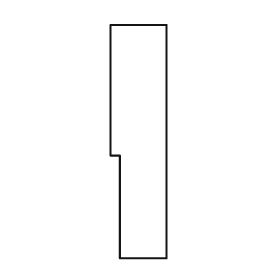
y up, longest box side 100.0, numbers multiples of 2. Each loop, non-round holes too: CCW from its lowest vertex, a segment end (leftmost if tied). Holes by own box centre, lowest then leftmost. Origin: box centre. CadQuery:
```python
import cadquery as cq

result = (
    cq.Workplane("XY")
    .moveTo(-8.0, -50.0)
    .lineTo(12.0, -50.0)
    .lineTo(12.0, 50.0)
    .lineTo(-12.0, 50.0)
    .lineTo(-12.0, -6.0)
    .lineTo(-8.0, -6.0)
    .close()
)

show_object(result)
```